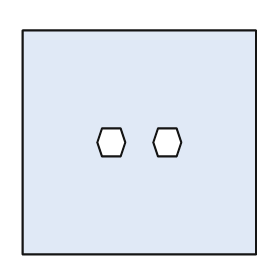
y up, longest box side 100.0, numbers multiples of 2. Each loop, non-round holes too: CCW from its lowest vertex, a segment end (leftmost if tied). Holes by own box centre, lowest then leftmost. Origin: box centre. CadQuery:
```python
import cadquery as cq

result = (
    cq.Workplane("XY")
    .moveTo(-50.0, -48.0)
    .lineTo(50.0, -48.0)
    .lineTo(50.0, 48.0)
    .lineTo(-50.0, 48.0)
    .close()
    .moveTo(-16.0, -6.0)
    .lineTo(-8.0, -6.0)
    .lineTo(-6.0, 0.0)
    .lineTo(-8.0, 6.0)
    .lineTo(-16.0, 6.0)
    .lineTo(-18.0, 0.0)
    .close()
    .moveTo(8.0, -6.0)
    .lineTo(16.0, -6.0)
    .lineTo(18.0, 0.0)
    .lineTo(16.0, 6.0)
    .lineTo(8.0, 6.0)
    .lineTo(6.0, 0.0)
    .close()
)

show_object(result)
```